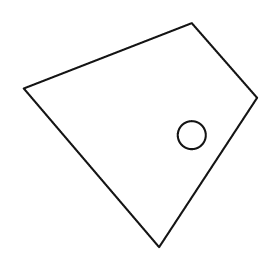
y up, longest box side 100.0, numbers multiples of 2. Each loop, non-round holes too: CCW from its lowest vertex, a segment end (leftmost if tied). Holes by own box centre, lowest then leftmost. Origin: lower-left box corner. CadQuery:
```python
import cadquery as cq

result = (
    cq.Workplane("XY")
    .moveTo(58.0, 0.0)
    .lineTo(100.0, 64.0)
    .lineTo(72.0, 96.0)
    .lineTo(0.0, 68.0)
    .close()
    .moveTo(72.0, 48.0)
    .circle(6.0)
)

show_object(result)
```